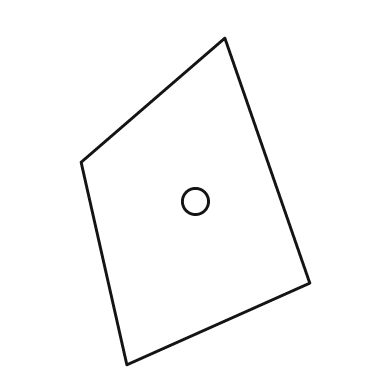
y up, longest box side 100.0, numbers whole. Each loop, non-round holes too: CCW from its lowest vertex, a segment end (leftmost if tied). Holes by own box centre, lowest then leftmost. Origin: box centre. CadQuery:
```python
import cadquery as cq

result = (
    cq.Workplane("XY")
    .moveTo(-21.0, -50.0)
    .lineTo(35.0, -25.0)
    .lineTo(9.0, 50.0)
    .lineTo(-35.0, 12.0)
    .close()
    .moveTo(0.0, 0.0)
    .circle(4.0)
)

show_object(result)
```